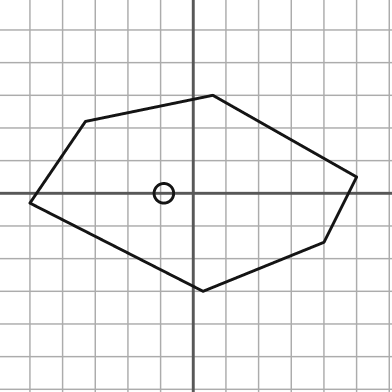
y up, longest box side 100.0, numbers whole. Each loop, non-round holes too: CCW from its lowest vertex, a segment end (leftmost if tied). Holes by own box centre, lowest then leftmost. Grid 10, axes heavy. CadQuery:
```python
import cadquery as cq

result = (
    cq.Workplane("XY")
    .moveTo(3.0, -30.0)
    .lineTo(40.0, -15.0)
    .lineTo(50.0, 5.0)
    .lineTo(6.0, 30.0)
    .lineTo(-33.0, 22.0)
    .lineTo(-50.0, -3.0)
    .close()
    .moveTo(-9.0, 0.0)
    .circle(3.0)
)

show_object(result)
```